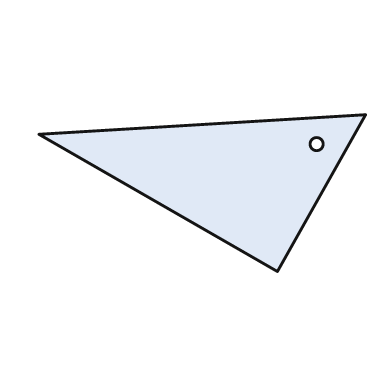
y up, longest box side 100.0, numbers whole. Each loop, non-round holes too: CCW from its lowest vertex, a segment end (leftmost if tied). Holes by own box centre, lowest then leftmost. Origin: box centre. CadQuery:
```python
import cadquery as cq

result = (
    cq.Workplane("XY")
    .moveTo(23.0, -24.0)
    .lineTo(50.0, 24.0)
    .lineTo(-50.0, 18.0)
    .close()
    .moveTo(35.0, 15.0)
    .circle(2.0)
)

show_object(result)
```